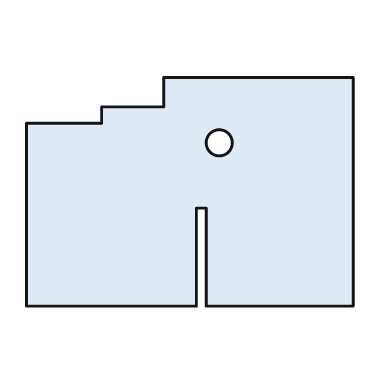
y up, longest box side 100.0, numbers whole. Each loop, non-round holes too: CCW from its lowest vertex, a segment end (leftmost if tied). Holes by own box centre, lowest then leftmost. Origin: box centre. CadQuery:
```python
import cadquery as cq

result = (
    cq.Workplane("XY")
    .moveTo(-50.0, -35.0)
    .lineTo(2.0, -35.0)
    .lineTo(2.0, -5.0)
    .lineTo(5.0, -5.0)
    .lineTo(5.0, -35.0)
    .lineTo(50.0, -35.0)
    .lineTo(50.0, 35.0)
    .lineTo(-8.0, 35.0)
    .lineTo(-8.0, 26.0)
    .lineTo(-27.0, 26.0)
    .lineTo(-27.0, 21.0)
    .lineTo(-50.0, 21.0)
    .close()
    .moveTo(9.0, 15.0)
    .circle(4.0)
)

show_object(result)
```